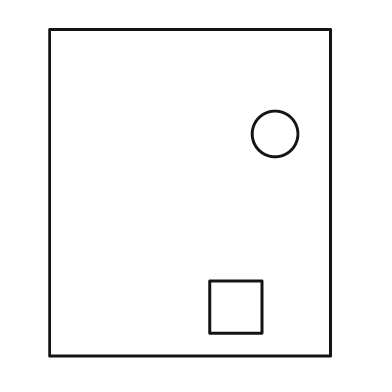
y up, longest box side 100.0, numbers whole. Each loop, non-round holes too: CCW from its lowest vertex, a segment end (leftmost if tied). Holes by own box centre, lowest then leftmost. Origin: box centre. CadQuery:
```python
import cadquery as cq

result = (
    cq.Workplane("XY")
    .moveTo(-43.0, -50.0)
    .lineTo(43.0, -50.0)
    .lineTo(43.0, 50.0)
    .lineTo(-43.0, 50.0)
    .close()
    .moveTo(6.0, -43.0)
    .lineTo(22.0, -43.0)
    .lineTo(22.0, -27.0)
    .lineTo(6.0, -27.0)
    .close()
    .moveTo(26.0, 18.0)
    .circle(7.0)
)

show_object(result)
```